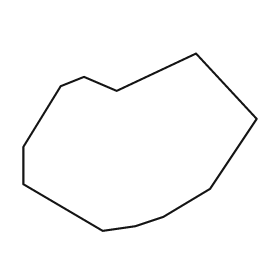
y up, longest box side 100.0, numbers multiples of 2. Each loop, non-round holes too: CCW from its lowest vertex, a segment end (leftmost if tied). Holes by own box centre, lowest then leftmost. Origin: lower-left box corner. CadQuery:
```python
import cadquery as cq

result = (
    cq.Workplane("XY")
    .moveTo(34.0, 0.0)
    .lineTo(48.0, 2.0)
    .lineTo(60.0, 6.0)
    .lineTo(80.0, 18.0)
    .lineTo(100.0, 48.0)
    .lineTo(74.0, 76.0)
    .lineTo(40.0, 60.0)
    .lineTo(26.0, 66.0)
    .lineTo(16.0, 62.0)
    .lineTo(0.0, 36.0)
    .lineTo(0.0, 20.0)
    .close()
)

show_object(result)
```